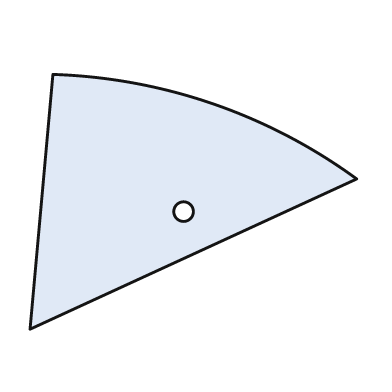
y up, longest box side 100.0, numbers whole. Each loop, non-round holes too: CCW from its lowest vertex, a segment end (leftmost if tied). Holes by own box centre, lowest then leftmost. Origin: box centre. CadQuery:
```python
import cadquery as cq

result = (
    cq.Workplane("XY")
    .moveTo(-50.0, -39.0)
    .lineTo(50.0, 7.0)
    .threePointArc((6.0, 30.0), (-43.0, 39.0))
    .close()
    .moveTo(-3.0, -3.0)
    .circle(3.0)
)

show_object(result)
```